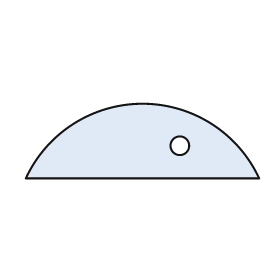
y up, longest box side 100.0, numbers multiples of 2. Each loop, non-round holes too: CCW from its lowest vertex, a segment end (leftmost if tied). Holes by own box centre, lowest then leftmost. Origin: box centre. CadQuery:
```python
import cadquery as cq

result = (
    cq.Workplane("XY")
    .moveTo(-50.0, -16.0)
    .lineTo(50.0, -16.0)
    .threePointArc((0.0, 16.0), (-50.0, -16.0))
    .close()
    .moveTo(16.0, -2.0)
    .circle(4.0)
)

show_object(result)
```